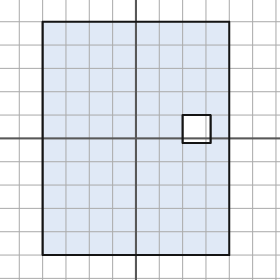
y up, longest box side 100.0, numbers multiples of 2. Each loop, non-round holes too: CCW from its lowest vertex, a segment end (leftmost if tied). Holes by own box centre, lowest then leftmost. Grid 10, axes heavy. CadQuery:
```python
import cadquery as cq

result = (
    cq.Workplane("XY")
    .moveTo(-40.0, -50.0)
    .lineTo(40.0, -50.0)
    .lineTo(40.0, 50.0)
    .lineTo(-40.0, 50.0)
    .close()
    .moveTo(20.0, -2.0)
    .lineTo(32.0, -2.0)
    .lineTo(32.0, 10.0)
    .lineTo(20.0, 10.0)
    .close()
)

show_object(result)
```